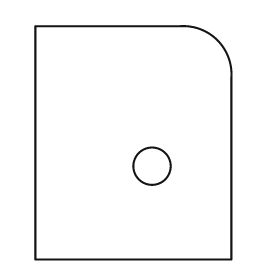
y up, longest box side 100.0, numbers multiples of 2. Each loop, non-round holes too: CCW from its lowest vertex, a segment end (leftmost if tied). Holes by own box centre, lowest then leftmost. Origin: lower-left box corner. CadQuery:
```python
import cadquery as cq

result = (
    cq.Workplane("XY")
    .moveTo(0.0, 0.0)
    .lineTo(84.0, 0.0)
    .lineTo(84.0, 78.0)
    .threePointArc((78.0, 94.0), (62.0, 100.0))
    .lineTo(0.0, 100.0)
    .close()
    .moveTo(50.0, 40.0)
    .circle(8.0)
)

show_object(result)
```